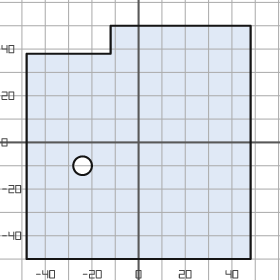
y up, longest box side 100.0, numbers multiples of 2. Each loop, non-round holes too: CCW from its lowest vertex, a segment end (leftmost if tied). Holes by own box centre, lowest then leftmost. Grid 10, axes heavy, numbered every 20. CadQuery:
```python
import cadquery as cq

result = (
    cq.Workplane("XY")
    .moveTo(-48.0, -50.0)
    .lineTo(48.0, -50.0)
    .lineTo(48.0, 50.0)
    .lineTo(-12.0, 50.0)
    .lineTo(-12.0, 38.0)
    .lineTo(-48.0, 38.0)
    .close()
    .moveTo(-24.0, -10.0)
    .circle(4.0)
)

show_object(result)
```